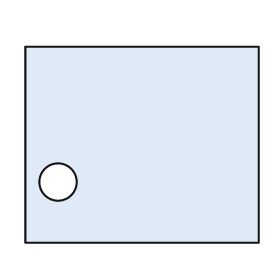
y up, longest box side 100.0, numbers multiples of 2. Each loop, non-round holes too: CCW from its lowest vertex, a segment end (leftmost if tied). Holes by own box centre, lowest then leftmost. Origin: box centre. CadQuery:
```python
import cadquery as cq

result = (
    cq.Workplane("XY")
    .moveTo(-50.0, -42.0)
    .lineTo(50.0, -42.0)
    .lineTo(50.0, 42.0)
    .lineTo(-50.0, 42.0)
    .close()
    .moveTo(-36.0, -16.0)
    .circle(8.0)
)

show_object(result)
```